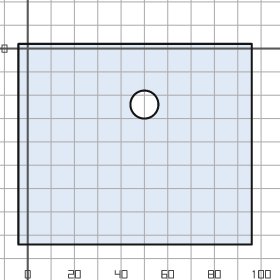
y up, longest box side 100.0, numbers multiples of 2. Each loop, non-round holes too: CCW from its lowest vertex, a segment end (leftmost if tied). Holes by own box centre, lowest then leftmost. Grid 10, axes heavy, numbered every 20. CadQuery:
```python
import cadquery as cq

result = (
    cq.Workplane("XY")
    .moveTo(-4.0, -84.0)
    .lineTo(96.0, -84.0)
    .lineTo(96.0, 2.0)
    .lineTo(-4.0, 2.0)
    .close()
    .moveTo(50.0, -24.0)
    .circle(6.0)
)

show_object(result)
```